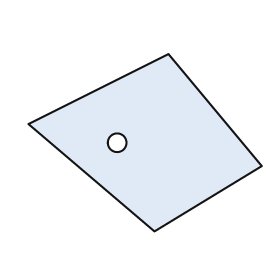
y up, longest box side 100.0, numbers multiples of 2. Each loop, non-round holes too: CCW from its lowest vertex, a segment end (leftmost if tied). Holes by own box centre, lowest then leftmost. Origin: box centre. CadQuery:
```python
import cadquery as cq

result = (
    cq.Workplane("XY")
    .moveTo(4.0, -38.0)
    .lineTo(50.0, -10.0)
    .lineTo(10.0, 38.0)
    .lineTo(-50.0, 8.0)
    .close()
    .moveTo(-12.0, 0.0)
    .circle(4.0)
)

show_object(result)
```